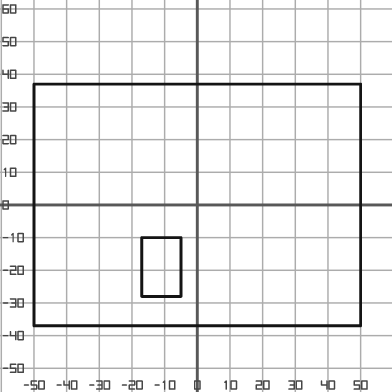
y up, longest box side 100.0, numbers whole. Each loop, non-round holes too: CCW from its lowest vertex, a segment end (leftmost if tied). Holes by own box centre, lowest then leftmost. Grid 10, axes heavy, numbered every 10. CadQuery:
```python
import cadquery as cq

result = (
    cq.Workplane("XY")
    .moveTo(-50.0, -37.0)
    .lineTo(50.0, -37.0)
    .lineTo(50.0, 37.0)
    .lineTo(-50.0, 37.0)
    .close()
    .moveTo(-17.0, -28.0)
    .lineTo(-5.0, -28.0)
    .lineTo(-5.0, -10.0)
    .lineTo(-17.0, -10.0)
    .close()
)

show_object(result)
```